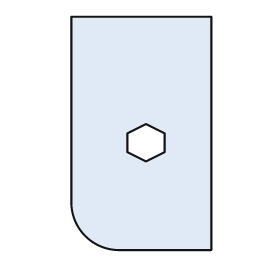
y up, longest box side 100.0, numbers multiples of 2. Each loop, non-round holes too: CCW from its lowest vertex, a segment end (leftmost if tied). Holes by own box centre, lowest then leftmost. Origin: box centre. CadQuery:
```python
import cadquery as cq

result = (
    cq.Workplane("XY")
    .moveTo(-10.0, -50.0)
    .lineTo(30.0, -50.0)
    .lineTo(30.0, 50.0)
    .lineTo(-30.0, 50.0)
    .lineTo(-30.0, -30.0)
    .threePointArc((-24.0, -44.0), (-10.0, -50.0))
    .close()
    .moveTo(2.0, -12.0)
    .lineTo(10.0, -8.0)
    .lineTo(10.0, 0.0)
    .lineTo(2.0, 4.0)
    .lineTo(-6.0, 0.0)
    .lineTo(-6.0, -8.0)
    .close()
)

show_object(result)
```